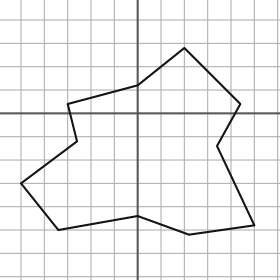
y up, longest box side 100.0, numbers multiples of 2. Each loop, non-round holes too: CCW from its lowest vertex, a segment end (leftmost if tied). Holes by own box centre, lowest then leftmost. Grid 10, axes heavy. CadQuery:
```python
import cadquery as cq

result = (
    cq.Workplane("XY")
    .moveTo(22.0, -52.0)
    .lineTo(50.0, -48.0)
    .lineTo(34.0, -14.0)
    .lineTo(44.0, 4.0)
    .lineTo(20.0, 28.0)
    .lineTo(0.0, 12.0)
    .lineTo(-30.0, 4.0)
    .lineTo(-26.0, -12.0)
    .lineTo(-50.0, -30.0)
    .lineTo(-34.0, -50.0)
    .lineTo(0.0, -44.0)
    .close()
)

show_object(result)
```